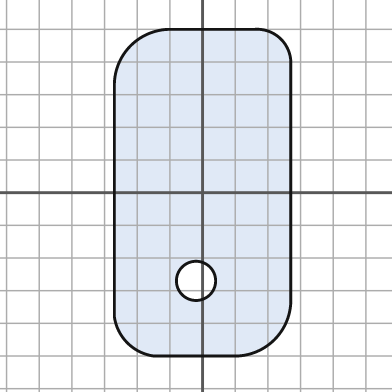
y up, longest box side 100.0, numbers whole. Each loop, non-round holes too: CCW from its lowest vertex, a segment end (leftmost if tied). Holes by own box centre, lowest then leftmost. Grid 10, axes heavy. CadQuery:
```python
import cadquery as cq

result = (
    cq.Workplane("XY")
    .moveTo(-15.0, -50.0)
    .lineTo(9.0, -50.0)
    .threePointArc((22.0, -45.0), (27.0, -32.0))
    .lineTo(27.0, 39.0)
    .threePointArc((24.0, 47.0), (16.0, 50.0))
    .lineTo(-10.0, 50.0)
    .threePointArc((-22.0, 45.0), (-27.0, 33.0))
    .lineTo(-27.0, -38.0)
    .threePointArc((-23.0, -46.0), (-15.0, -50.0))
    .close()
    .moveTo(-2.0, -27.0)
    .circle(6.0)
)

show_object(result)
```